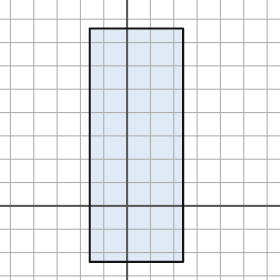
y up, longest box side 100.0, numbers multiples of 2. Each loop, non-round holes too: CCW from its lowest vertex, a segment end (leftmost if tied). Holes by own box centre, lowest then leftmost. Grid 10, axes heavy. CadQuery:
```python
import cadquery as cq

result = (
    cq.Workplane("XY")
    .moveTo(-16.0, -24.0)
    .lineTo(24.0, -24.0)
    .lineTo(24.0, 76.0)
    .lineTo(-16.0, 76.0)
    .close()
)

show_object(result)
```